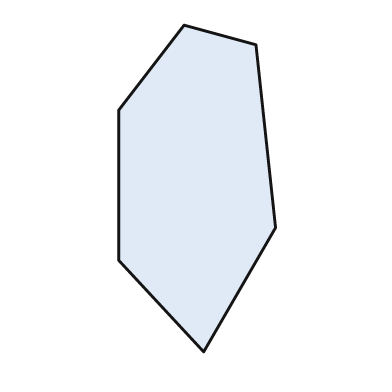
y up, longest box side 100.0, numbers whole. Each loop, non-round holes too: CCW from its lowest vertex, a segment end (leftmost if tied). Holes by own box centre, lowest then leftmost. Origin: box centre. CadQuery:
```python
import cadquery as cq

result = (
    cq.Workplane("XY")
    .moveTo(2.0, -50.0)
    .lineTo(24.0, -12.0)
    .lineTo(18.0, 44.0)
    .lineTo(-4.0, 50.0)
    .lineTo(-24.0, 24.0)
    .lineTo(-24.0, -22.0)
    .close()
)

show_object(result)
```